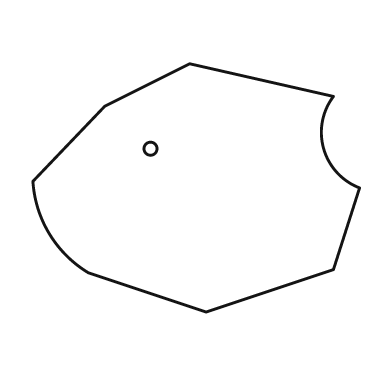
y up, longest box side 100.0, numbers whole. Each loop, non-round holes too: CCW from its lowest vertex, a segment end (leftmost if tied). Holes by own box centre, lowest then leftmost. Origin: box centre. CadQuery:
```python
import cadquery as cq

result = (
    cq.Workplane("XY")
    .moveTo(3.0, -38.0)
    .lineTo(42.0, -25.0)
    .lineTo(50.0, 0.0)
    .threePointArc((39.0, 12.0), (42.0, 28.0))
    .lineTo(-2.0, 38.0)
    .lineTo(-28.0, 25.0)
    .lineTo(-50.0, 2.0)
    .threePointArc((-45.0, -14.0), (-33.0, -26.0))
    .close()
    .moveTo(-14.0, 12.0)
    .circle(2.0)
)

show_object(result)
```